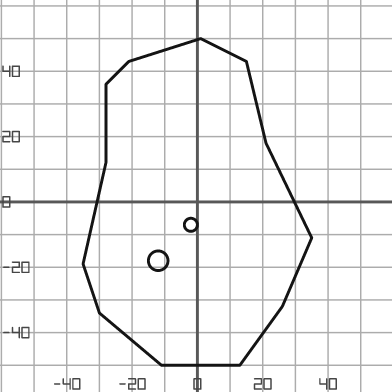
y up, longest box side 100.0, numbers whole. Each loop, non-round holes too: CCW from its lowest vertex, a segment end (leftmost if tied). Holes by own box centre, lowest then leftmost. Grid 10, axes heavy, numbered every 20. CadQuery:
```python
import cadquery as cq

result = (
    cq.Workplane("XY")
    .moveTo(-11.0, -50.0)
    .lineTo(13.0, -50.0)
    .lineTo(26.0, -32.0)
    .lineTo(35.0, -11.0)
    .lineTo(21.0, 18.0)
    .lineTo(15.0, 43.0)
    .lineTo(1.0, 50.0)
    .lineTo(-21.0, 43.0)
    .lineTo(-28.0, 36.0)
    .lineTo(-28.0, 12.0)
    .lineTo(-35.0, -19.0)
    .lineTo(-30.0, -34.0)
    .close()
    .moveTo(-12.0, -18.0)
    .circle(3.0)
    .moveTo(-2.0, -7.0)
    .circle(2.0)
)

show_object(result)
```